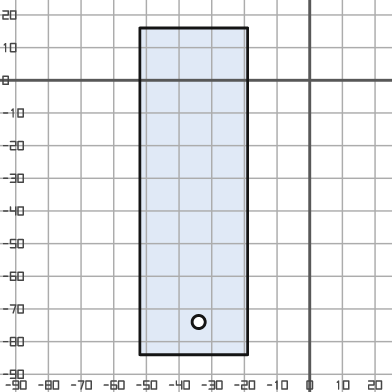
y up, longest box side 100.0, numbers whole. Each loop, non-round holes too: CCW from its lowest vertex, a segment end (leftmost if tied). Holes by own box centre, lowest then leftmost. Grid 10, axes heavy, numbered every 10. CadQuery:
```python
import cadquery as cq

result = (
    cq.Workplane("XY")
    .moveTo(-52.0, -84.0)
    .lineTo(-19.0, -84.0)
    .lineTo(-19.0, 16.0)
    .lineTo(-52.0, 16.0)
    .close()
    .moveTo(-34.0, -74.0)
    .circle(2.0)
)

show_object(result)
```